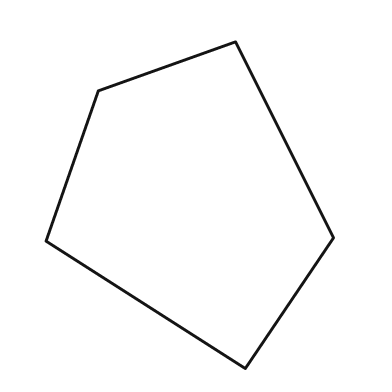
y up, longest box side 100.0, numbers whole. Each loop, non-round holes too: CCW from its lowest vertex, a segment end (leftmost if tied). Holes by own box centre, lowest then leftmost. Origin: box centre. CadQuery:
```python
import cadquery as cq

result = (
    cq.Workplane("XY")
    .moveTo(17.0, -50.0)
    .lineTo(44.0, -10.0)
    .lineTo(14.0, 50.0)
    .lineTo(-28.0, 35.0)
    .lineTo(-44.0, -11.0)
    .close()
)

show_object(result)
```